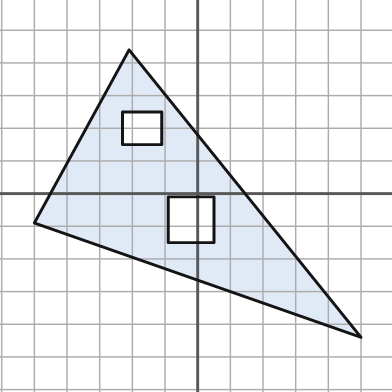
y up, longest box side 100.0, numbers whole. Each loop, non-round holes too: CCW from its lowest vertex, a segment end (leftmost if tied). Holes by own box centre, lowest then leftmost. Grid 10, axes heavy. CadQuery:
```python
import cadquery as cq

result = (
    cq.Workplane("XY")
    .moveTo(50.0, -44.0)
    .lineTo(-21.0, 44.0)
    .lineTo(-50.0, -9.0)
    .close()
    .moveTo(-9.0, -15.0)
    .lineTo(5.0, -15.0)
    .lineTo(5.0, -1.0)
    .lineTo(-9.0, -1.0)
    .close()
    .moveTo(-23.0, 15.0)
    .lineTo(-11.0, 15.0)
    .lineTo(-11.0, 25.0)
    .lineTo(-23.0, 25.0)
    .close()
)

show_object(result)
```